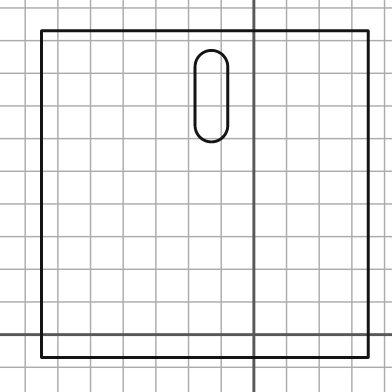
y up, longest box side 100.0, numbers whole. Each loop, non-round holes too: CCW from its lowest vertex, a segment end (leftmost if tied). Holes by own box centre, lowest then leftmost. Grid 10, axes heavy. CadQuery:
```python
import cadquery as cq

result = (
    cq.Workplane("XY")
    .moveTo(-65.0, -7.0)
    .lineTo(35.0, -7.0)
    .lineTo(35.0, 93.0)
    .lineTo(-65.0, 93.0)
    .close()
    .moveTo(-18.0, 64.0)
    .threePointArc((-13.0, 59.0), (-8.0, 64.0))
    .lineTo(-8.0, 82.0)
    .threePointArc((-13.0, 87.0), (-18.0, 82.0))
    .close()
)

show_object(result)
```